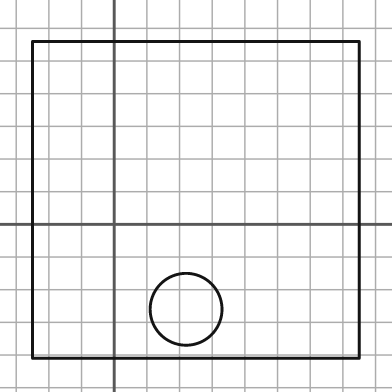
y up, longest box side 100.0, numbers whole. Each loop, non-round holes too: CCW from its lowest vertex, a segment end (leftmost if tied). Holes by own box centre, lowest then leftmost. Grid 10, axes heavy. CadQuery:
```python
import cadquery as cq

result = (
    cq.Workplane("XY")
    .moveTo(-25.0, -41.0)
    .lineTo(75.0, -41.0)
    .lineTo(75.0, 56.0)
    .lineTo(-25.0, 56.0)
    .close()
    .moveTo(22.0, -26.0)
    .circle(11.0)
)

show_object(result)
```